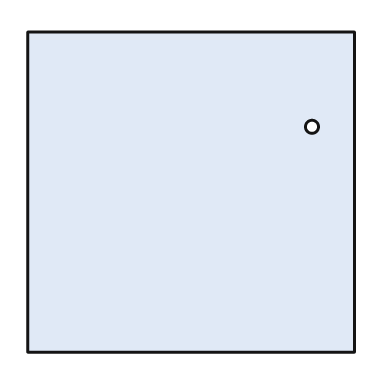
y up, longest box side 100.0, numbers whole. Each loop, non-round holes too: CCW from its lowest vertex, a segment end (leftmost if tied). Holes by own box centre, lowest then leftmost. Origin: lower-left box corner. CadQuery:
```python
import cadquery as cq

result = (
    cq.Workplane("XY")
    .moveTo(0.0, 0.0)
    .lineTo(100.0, 0.0)
    .lineTo(100.0, 98.0)
    .lineTo(0.0, 98.0)
    .close()
    .moveTo(87.0, 69.0)
    .circle(2.0)
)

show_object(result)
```